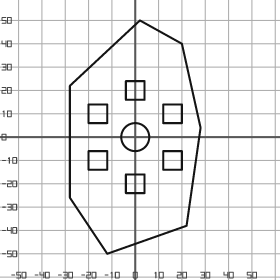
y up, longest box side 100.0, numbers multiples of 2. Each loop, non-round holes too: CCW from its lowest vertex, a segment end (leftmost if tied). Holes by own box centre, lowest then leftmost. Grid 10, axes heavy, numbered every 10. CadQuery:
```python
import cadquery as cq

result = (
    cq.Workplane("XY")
    .moveTo(-12.0, -50.0)
    .lineTo(22.0, -38.0)
    .lineTo(28.0, 4.0)
    .lineTo(20.0, 40.0)
    .lineTo(2.0, 50.0)
    .lineTo(-28.0, 22.0)
    .lineTo(-28.0, -26.0)
    .close()
    .moveTo(-4.0, -24.0)
    .lineTo(4.0, -24.0)
    .lineTo(4.0, -16.0)
    .lineTo(-4.0, -16.0)
    .close()
    .moveTo(-20.0, -14.0)
    .lineTo(-12.0, -14.0)
    .lineTo(-12.0, -6.0)
    .lineTo(-20.0, -6.0)
    .close()
    .moveTo(12.0, -14.0)
    .lineTo(20.0, -14.0)
    .lineTo(20.0, -6.0)
    .lineTo(12.0, -6.0)
    .close()
    .moveTo(0.0, 0.0)
    .circle(6.0)
    .moveTo(-20.0, 6.0)
    .lineTo(-12.0, 6.0)
    .lineTo(-12.0, 14.0)
    .lineTo(-20.0, 14.0)
    .close()
    .moveTo(12.0, 6.0)
    .lineTo(20.0, 6.0)
    .lineTo(20.0, 14.0)
    .lineTo(12.0, 14.0)
    .close()
    .moveTo(-4.0, 16.0)
    .lineTo(4.0, 16.0)
    .lineTo(4.0, 24.0)
    .lineTo(-4.0, 24.0)
    .close()
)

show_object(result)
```